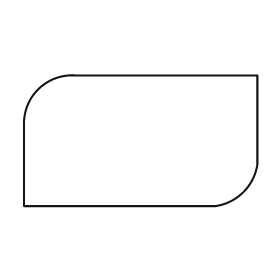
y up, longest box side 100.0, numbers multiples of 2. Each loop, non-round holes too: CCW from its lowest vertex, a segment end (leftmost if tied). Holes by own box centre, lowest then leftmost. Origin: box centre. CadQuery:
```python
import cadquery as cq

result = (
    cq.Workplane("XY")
    .moveTo(-50.0, -28.0)
    .lineTo(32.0, -28.0)
    .threePointArc((44.0, -22.0), (50.0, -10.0))
    .lineTo(50.0, 28.0)
    .lineTo(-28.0, 28.0)
    .threePointArc((-44.0, 22.0), (-50.0, 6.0))
    .close()
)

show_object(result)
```